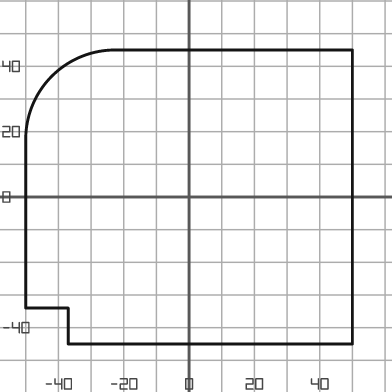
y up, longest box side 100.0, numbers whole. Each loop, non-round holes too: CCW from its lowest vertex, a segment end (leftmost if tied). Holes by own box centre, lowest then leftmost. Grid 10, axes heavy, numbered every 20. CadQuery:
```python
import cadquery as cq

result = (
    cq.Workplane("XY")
    .moveTo(-37.0, -45.0)
    .lineTo(50.0, -45.0)
    .lineTo(50.0, 45.0)
    .lineTo(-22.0, 45.0)
    .threePointArc((-42.0, 37.0), (-50.0, 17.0))
    .lineTo(-50.0, -34.0)
    .lineTo(-37.0, -34.0)
    .close()
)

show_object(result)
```